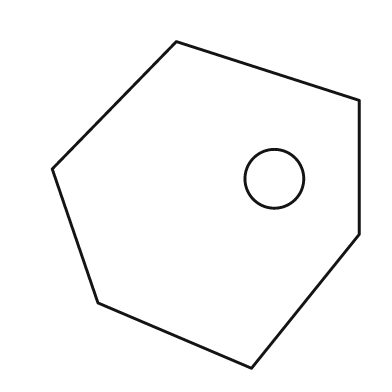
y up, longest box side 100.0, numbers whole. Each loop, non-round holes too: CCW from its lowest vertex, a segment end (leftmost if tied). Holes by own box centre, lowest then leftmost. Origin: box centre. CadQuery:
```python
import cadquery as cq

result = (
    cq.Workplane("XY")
    .moveTo(14.0, -50.0)
    .lineTo(47.0, -9.0)
    .lineTo(47.0, 32.0)
    .lineTo(-9.0, 50.0)
    .lineTo(-47.0, 11.0)
    .lineTo(-33.0, -30.0)
    .close()
    .moveTo(21.0, 8.0)
    .circle(9.0)
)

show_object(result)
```